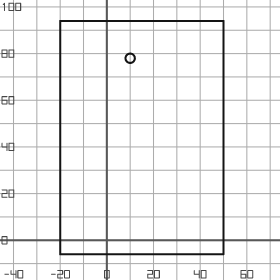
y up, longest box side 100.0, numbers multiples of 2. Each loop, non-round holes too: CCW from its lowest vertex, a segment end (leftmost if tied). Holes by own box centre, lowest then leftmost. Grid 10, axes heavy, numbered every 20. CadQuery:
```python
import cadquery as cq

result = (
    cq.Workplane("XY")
    .moveTo(-20.0, -6.0)
    .lineTo(50.0, -6.0)
    .lineTo(50.0, 94.0)
    .lineTo(-20.0, 94.0)
    .close()
    .moveTo(10.0, 78.0)
    .circle(2.0)
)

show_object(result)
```